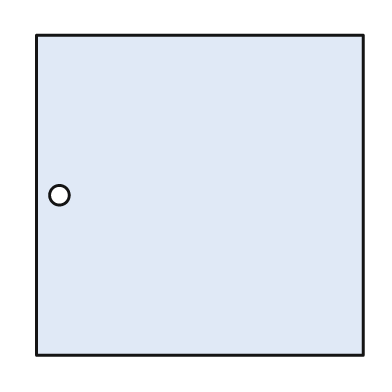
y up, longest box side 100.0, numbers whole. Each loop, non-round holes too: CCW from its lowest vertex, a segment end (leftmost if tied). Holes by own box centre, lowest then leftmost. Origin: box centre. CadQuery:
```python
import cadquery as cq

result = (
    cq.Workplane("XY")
    .moveTo(-50.0, -49.0)
    .lineTo(50.0, -49.0)
    .lineTo(50.0, 49.0)
    .lineTo(-50.0, 49.0)
    .close()
    .moveTo(-43.0, 0.0)
    .circle(3.0)
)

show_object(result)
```